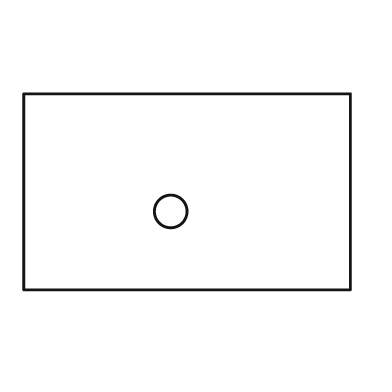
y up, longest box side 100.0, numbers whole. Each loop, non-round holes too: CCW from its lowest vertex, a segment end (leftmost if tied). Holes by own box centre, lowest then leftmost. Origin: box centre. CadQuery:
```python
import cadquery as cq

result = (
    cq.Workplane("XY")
    .moveTo(-50.0, -30.0)
    .lineTo(50.0, -30.0)
    .lineTo(50.0, 30.0)
    .lineTo(-50.0, 30.0)
    .close()
    .moveTo(-5.0, -6.0)
    .circle(5.0)
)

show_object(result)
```